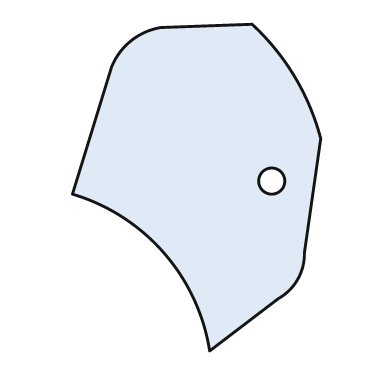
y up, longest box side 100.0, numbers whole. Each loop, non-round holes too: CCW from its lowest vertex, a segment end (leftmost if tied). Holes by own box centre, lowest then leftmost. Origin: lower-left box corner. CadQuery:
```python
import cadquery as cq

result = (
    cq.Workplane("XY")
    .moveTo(42.0, 0.0)
    .lineTo(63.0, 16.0)
    .threePointArc((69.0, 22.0), (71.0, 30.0))
    .lineTo(76.0, 65.0)
    .threePointArc((68.0, 84.0), (55.0, 100.0))
    .lineTo(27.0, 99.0)
    .threePointArc((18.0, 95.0), (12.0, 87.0))
    .lineTo(0.0, 48.0)
    .threePointArc((28.0, 30.0), (42.0, 0.0))
    .close()
    .moveTo(61.0, 52.0)
    .circle(4.0)
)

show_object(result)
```